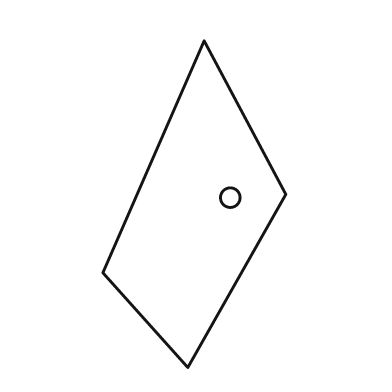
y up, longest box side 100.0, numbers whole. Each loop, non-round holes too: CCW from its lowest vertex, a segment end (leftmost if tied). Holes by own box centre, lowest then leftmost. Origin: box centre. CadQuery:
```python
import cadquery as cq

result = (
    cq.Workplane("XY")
    .moveTo(-2.0, -50.0)
    .lineTo(28.0, 3.0)
    .lineTo(3.0, 50.0)
    .lineTo(-28.0, -21.0)
    .close()
    .moveTo(11.0, 2.0)
    .circle(3.0)
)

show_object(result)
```